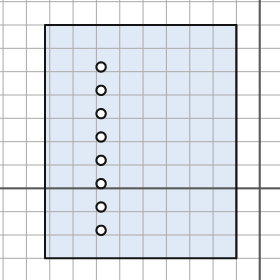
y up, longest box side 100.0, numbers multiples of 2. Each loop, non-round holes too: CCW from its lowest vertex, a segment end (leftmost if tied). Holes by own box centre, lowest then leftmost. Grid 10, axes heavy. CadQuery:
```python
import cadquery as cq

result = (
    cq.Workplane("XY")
    .moveTo(-92.0, -30.0)
    .lineTo(-10.0, -30.0)
    .lineTo(-10.0, 70.0)
    .lineTo(-92.0, 70.0)
    .close()
    .moveTo(-68.0, -18.0)
    .circle(2.0)
    .moveTo(-68.0, -8.0)
    .circle(2.0)
    .moveTo(-68.0, 2.0)
    .circle(2.0)
    .moveTo(-68.0, 12.0)
    .circle(2.0)
    .moveTo(-68.0, 22.0)
    .circle(2.0)
    .moveTo(-68.0, 32.0)
    .circle(2.0)
    .moveTo(-68.0, 42.0)
    .circle(2.0)
    .moveTo(-68.0, 52.0)
    .circle(2.0)
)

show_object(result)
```